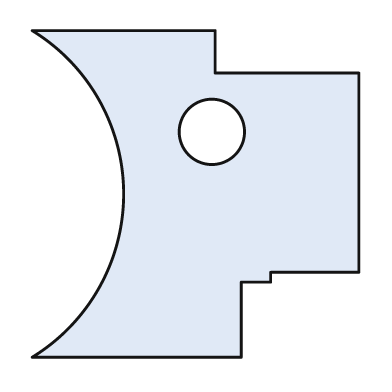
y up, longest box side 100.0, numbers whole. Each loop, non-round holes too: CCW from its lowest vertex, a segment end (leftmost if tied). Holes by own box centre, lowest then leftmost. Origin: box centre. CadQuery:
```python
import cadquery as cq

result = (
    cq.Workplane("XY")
    .moveTo(-50.0, -50.0)
    .lineTo(14.0, -50.0)
    .lineTo(14.0, -27.0)
    .lineTo(23.0, -27.0)
    .lineTo(23.0, -24.0)
    .lineTo(50.0, -24.0)
    .lineTo(50.0, 37.0)
    .lineTo(6.0, 37.0)
    .lineTo(6.0, 50.0)
    .lineTo(-50.0, 50.0)
    .threePointArc((-22.0, 0.0), (-50.0, -50.0))
    .close()
    .moveTo(5.0, 19.0)
    .circle(10.0)
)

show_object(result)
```